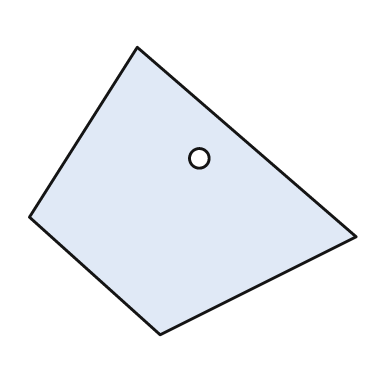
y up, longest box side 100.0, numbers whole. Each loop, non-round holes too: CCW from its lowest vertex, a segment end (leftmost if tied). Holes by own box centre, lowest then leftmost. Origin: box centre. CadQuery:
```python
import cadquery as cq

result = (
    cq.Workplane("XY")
    .moveTo(-10.0, -44.0)
    .lineTo(50.0, -14.0)
    .lineTo(-17.0, 44.0)
    .lineTo(-50.0, -8.0)
    .close()
    .moveTo(2.0, 10.0)
    .circle(3.0)
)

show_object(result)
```